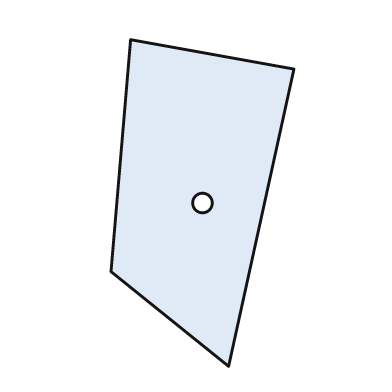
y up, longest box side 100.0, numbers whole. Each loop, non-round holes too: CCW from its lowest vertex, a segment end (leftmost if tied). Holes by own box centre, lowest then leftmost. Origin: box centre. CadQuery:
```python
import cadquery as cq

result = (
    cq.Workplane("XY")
    .moveTo(8.0, -50.0)
    .lineTo(28.0, 41.0)
    .lineTo(-22.0, 50.0)
    .lineTo(-28.0, -21.0)
    .close()
    .moveTo(0.0, 0.0)
    .circle(3.0)
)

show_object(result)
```